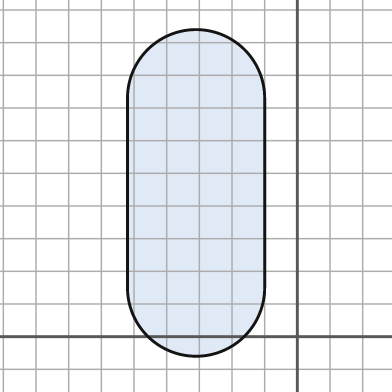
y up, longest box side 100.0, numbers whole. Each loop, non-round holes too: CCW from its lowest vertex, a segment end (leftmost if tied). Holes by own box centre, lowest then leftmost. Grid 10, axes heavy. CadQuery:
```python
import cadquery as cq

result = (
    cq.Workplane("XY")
    .moveTo(-52.0, 15.0)
    .threePointArc((-31.0, -6.0), (-10.0, 15.0))
    .lineTo(-10.0, 73.0)
    .threePointArc((-31.0, 94.0), (-52.0, 73.0))
    .close()
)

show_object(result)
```